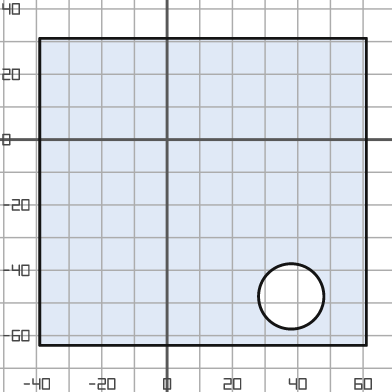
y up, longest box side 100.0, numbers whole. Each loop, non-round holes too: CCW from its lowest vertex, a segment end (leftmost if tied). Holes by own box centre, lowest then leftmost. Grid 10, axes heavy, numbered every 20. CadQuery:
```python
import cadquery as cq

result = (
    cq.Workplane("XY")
    .moveTo(-39.0, -63.0)
    .lineTo(61.0, -63.0)
    .lineTo(61.0, 31.0)
    .lineTo(-39.0, 31.0)
    .close()
    .moveTo(38.0, -48.0)
    .circle(10.0)
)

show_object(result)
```